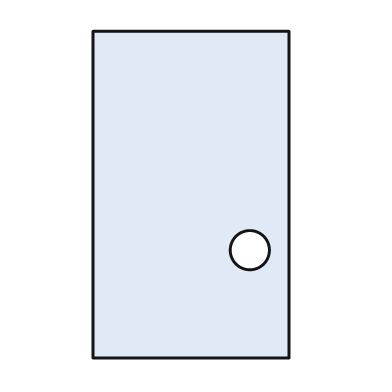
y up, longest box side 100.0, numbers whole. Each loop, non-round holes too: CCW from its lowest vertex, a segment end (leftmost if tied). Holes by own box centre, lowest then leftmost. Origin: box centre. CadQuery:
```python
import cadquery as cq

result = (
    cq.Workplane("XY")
    .moveTo(-30.0, -50.0)
    .lineTo(30.0, -50.0)
    .lineTo(30.0, 50.0)
    .lineTo(-30.0, 50.0)
    .close()
    .moveTo(18.0, -17.0)
    .circle(6.0)
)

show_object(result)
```